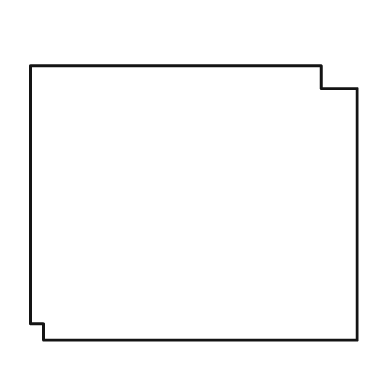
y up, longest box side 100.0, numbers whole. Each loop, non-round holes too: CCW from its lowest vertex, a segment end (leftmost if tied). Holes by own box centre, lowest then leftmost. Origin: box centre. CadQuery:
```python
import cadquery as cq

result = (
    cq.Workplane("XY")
    .moveTo(-46.0, -42.0)
    .lineTo(50.0, -42.0)
    .lineTo(50.0, 35.0)
    .lineTo(39.0, 35.0)
    .lineTo(39.0, 42.0)
    .lineTo(-50.0, 42.0)
    .lineTo(-50.0, -37.0)
    .lineTo(-46.0, -37.0)
    .close()
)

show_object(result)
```